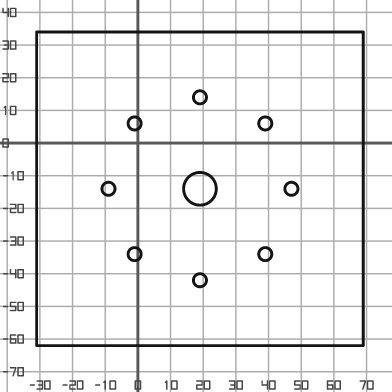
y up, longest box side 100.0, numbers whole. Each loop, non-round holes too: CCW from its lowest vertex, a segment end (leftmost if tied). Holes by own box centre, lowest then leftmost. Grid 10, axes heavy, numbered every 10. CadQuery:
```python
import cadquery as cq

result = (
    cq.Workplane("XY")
    .moveTo(-31.0, -62.0)
    .lineTo(69.0, -62.0)
    .lineTo(69.0, 34.0)
    .lineTo(-31.0, 34.0)
    .close()
    .moveTo(19.0, -42.0)
    .circle(2.0)
    .moveTo(-1.0, -34.0)
    .circle(2.0)
    .moveTo(39.0, -34.0)
    .circle(2.0)
    .moveTo(-9.0, -14.0)
    .circle(2.0)
    .moveTo(19.0, -14.0)
    .circle(5.0)
    .moveTo(47.0, -14.0)
    .circle(2.0)
    .moveTo(-1.0, 6.0)
    .circle(2.0)
    .moveTo(39.0, 6.0)
    .circle(2.0)
    .moveTo(19.0, 14.0)
    .circle(2.0)
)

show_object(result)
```